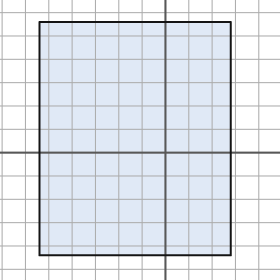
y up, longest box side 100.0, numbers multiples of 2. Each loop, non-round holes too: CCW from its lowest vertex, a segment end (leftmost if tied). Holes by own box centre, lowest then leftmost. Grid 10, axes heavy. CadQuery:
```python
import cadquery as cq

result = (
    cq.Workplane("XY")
    .moveTo(-54.0, -44.0)
    .lineTo(28.0, -44.0)
    .lineTo(28.0, 56.0)
    .lineTo(-54.0, 56.0)
    .close()
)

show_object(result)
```